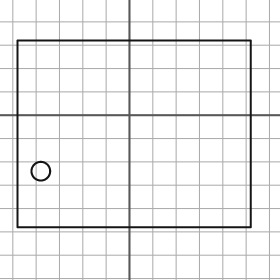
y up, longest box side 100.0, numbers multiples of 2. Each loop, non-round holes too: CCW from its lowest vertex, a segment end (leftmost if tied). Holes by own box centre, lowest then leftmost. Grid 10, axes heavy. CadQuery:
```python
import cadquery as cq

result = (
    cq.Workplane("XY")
    .moveTo(-48.0, -48.0)
    .lineTo(52.0, -48.0)
    .lineTo(52.0, 32.0)
    .lineTo(-48.0, 32.0)
    .close()
    .moveTo(-38.0, -24.0)
    .circle(4.0)
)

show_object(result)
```